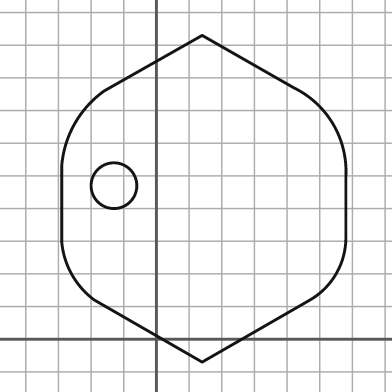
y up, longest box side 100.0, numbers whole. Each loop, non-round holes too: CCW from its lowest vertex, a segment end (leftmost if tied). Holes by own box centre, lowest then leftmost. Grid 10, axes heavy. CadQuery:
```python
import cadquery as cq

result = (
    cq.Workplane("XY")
    .moveTo(14.0, -7.0)
    .lineTo(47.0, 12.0)
    .threePointArc((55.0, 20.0), (58.0, 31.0))
    .lineTo(58.0, 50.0)
    .threePointArc((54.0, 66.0), (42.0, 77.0))
    .lineTo(14.0, 93.0)
    .lineTo(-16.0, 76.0)
    .threePointArc((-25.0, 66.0), (-29.0, 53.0))
    .lineTo(-29.0, 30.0)
    .threePointArc((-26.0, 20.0), (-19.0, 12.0))
    .close()
    .moveTo(-13.0, 47.0)
    .circle(7.0)
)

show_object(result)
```